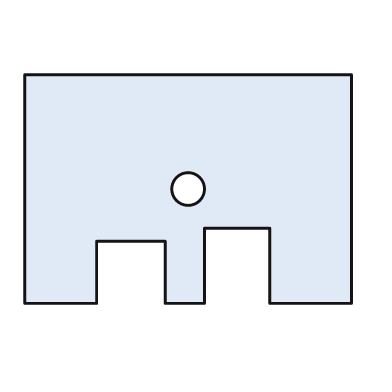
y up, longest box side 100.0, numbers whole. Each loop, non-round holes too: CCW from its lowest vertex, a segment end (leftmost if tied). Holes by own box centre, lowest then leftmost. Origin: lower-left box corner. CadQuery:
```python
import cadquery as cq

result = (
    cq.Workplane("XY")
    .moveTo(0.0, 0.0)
    .lineTo(22.0, 0.0)
    .lineTo(22.0, 19.0)
    .lineTo(43.0, 19.0)
    .lineTo(43.0, 0.0)
    .lineTo(55.0, 0.0)
    .lineTo(55.0, 23.0)
    .lineTo(75.0, 23.0)
    .lineTo(75.0, 0.0)
    .lineTo(100.0, 0.0)
    .lineTo(100.0, 70.0)
    .lineTo(0.0, 70.0)
    .close()
    .moveTo(50.0, 35.0)
    .circle(5.0)
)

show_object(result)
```